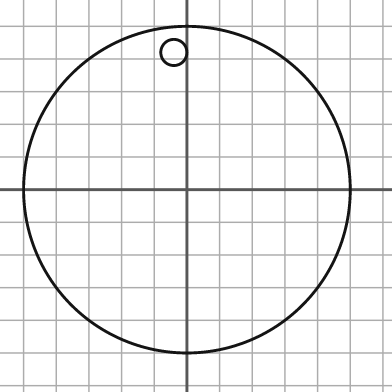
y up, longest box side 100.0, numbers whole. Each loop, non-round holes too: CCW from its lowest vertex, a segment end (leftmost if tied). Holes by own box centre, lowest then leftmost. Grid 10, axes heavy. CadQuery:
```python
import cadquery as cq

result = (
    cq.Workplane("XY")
    .moveTo(0.0, 0.0)
    .circle(50.0)
    .moveTo(-4.0, 42.0)
    .circle(4.0)
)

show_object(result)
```